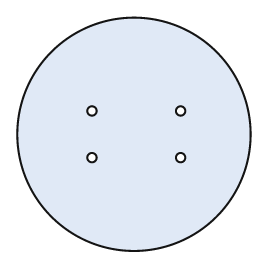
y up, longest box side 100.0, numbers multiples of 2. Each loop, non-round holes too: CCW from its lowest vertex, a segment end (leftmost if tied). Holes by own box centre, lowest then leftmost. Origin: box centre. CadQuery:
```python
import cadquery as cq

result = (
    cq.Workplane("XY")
    .moveTo(0.0, 0.0)
    .circle(50.0)
    .moveTo(-18.0, -10.0)
    .circle(2.0)
    .moveTo(20.0, -10.0)
    .circle(2.0)
    .moveTo(-18.0, 10.0)
    .circle(2.0)
    .moveTo(20.0, 10.0)
    .circle(2.0)
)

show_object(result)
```